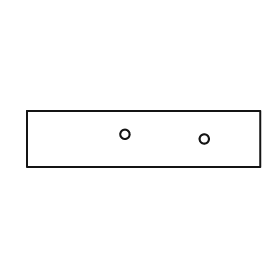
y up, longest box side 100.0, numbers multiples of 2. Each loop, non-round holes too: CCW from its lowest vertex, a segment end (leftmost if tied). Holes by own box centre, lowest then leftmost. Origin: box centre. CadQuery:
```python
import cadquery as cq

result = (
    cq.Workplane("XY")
    .moveTo(-50.0, -12.0)
    .lineTo(50.0, -12.0)
    .lineTo(50.0, 12.0)
    .lineTo(-50.0, 12.0)
    .close()
    .moveTo(26.0, 0.0)
    .circle(2.0)
    .moveTo(-8.0, 2.0)
    .circle(2.0)
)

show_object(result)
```